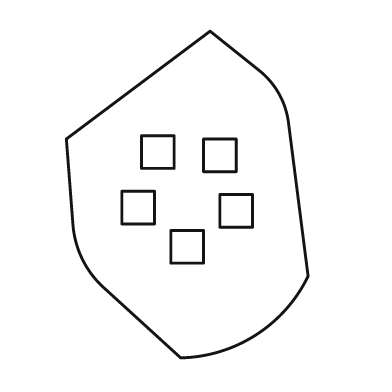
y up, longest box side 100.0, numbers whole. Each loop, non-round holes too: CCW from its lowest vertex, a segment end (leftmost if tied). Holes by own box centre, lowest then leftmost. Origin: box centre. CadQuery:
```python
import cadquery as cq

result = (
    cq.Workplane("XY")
    .moveTo(-2.0, -50.0)
    .threePointArc((21.0, -43.0), (37.0, -25.0))
    .lineTo(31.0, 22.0)
    .threePointArc((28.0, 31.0), (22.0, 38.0))
    .lineTo(7.0, 50.0)
    .lineTo(-37.0, 17.0)
    .lineTo(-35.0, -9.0)
    .threePointArc((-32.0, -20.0), (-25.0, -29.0))
    .close()
    .moveTo(-5.0, -21.0)
    .lineTo(5.0, -21.0)
    .lineTo(5.0, -11.0)
    .lineTo(-5.0, -11.0)
    .close()
    .moveTo(10.0, -10.0)
    .lineTo(20.0, -10.0)
    .lineTo(20.0, 0.0)
    .lineTo(10.0, 0.0)
    .close()
    .moveTo(-20.0, -9.0)
    .lineTo(-10.0, -9.0)
    .lineTo(-10.0, 1.0)
    .lineTo(-20.0, 1.0)
    .close()
    .moveTo(5.0, 7.0)
    .lineTo(15.0, 7.0)
    .lineTo(15.0, 17.0)
    .lineTo(5.0, 17.0)
    .close()
    .moveTo(-14.0, 8.0)
    .lineTo(-4.0, 8.0)
    .lineTo(-4.0, 18.0)
    .lineTo(-14.0, 18.0)
    .close()
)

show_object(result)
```